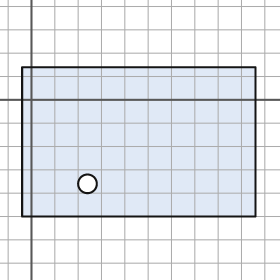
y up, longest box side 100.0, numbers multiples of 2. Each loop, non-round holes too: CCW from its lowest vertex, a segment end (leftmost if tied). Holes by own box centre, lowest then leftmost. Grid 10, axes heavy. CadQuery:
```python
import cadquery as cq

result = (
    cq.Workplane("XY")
    .moveTo(-4.0, -50.0)
    .lineTo(96.0, -50.0)
    .lineTo(96.0, 14.0)
    .lineTo(-4.0, 14.0)
    .close()
    .moveTo(24.0, -36.0)
    .circle(4.0)
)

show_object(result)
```